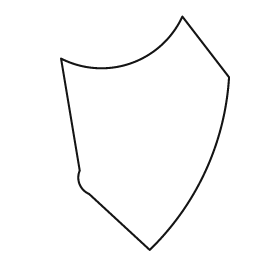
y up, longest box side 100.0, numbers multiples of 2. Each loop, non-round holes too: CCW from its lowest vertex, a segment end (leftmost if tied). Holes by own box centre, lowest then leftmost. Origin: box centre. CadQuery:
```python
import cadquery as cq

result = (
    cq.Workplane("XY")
    .moveTo(2.0, -50.0)
    .threePointArc((26.0, -16.0), (36.0, 24.0))
    .lineTo(16.0, 50.0)
    .threePointArc((-6.0, 30.0), (-36.0, 32.0))
    .lineTo(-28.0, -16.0)
    .threePointArc((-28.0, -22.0), (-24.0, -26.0))
    .close()
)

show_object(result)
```